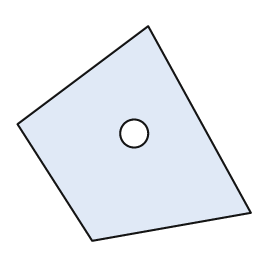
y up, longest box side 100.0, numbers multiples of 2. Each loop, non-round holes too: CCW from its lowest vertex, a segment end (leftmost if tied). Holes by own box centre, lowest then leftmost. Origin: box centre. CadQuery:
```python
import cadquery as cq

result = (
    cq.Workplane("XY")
    .moveTo(-18.0, -46.0)
    .lineTo(50.0, -34.0)
    .lineTo(6.0, 46.0)
    .lineTo(-50.0, 4.0)
    .close()
    .moveTo(0.0, 0.0)
    .circle(6.0)
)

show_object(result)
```